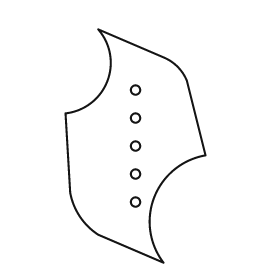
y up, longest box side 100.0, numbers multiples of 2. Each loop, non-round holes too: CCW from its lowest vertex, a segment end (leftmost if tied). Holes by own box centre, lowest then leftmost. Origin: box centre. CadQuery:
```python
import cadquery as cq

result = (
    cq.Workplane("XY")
    .moveTo(12.0, -50.0)
    .threePointArc((8.0, -22.0), (30.0, -4.0))
    .lineTo(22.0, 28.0)
    .threePointArc((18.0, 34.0), (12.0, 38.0))
    .lineTo(-16.0, 50.0)
    .threePointArc((-12.0, 28.0), (-30.0, 14.0))
    .lineTo(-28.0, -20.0)
    .threePointArc((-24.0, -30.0), (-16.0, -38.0))
    .close()
    .moveTo(0.0, -24.0)
    .circle(2.0)
    .moveTo(0.0, -12.0)
    .circle(2.0)
    .moveTo(0.0, 0.0)
    .circle(2.0)
    .moveTo(0.0, 12.0)
    .circle(2.0)
    .moveTo(0.0, 24.0)
    .circle(2.0)
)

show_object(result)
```